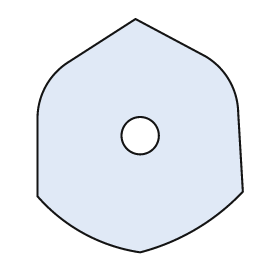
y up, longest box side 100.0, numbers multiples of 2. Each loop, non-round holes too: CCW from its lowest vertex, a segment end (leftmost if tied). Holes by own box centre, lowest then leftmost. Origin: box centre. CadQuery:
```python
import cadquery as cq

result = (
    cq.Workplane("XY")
    .moveTo(0.0, -50.0)
    .threePointArc((24.0, -40.0), (44.0, -24.0))
    .lineTo(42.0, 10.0)
    .threePointArc((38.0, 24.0), (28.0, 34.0))
    .lineTo(-2.0, 50.0)
    .lineTo(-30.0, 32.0)
    .threePointArc((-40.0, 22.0), (-44.0, 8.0))
    .lineTo(-44.0, -26.0)
    .threePointArc((-24.0, -42.0), (0.0, -50.0))
    .close()
    .moveTo(0.0, 0.0)
    .circle(8.0)
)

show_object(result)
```